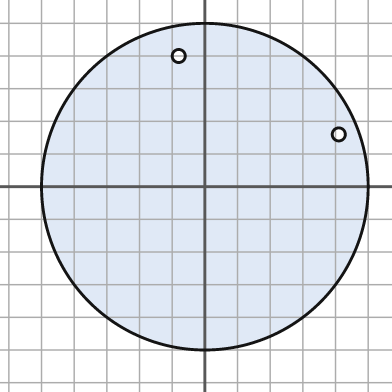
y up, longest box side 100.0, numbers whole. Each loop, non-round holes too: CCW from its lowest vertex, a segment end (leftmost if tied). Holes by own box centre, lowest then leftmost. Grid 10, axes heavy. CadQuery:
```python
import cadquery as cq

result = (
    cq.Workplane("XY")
    .moveTo(0.0, 0.0)
    .circle(50.0)
    .moveTo(41.0, 16.0)
    .circle(2.0)
    .moveTo(-8.0, 40.0)
    .circle(2.0)
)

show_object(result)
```